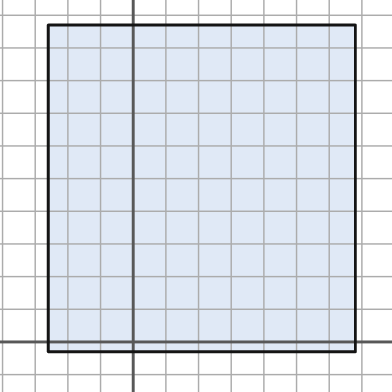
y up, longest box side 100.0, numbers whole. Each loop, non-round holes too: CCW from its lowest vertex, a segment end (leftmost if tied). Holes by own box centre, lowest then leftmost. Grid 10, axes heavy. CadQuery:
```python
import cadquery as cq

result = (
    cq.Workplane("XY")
    .moveTo(-26.0, -3.0)
    .lineTo(68.0, -3.0)
    .lineTo(68.0, 97.0)
    .lineTo(-26.0, 97.0)
    .close()
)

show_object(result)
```